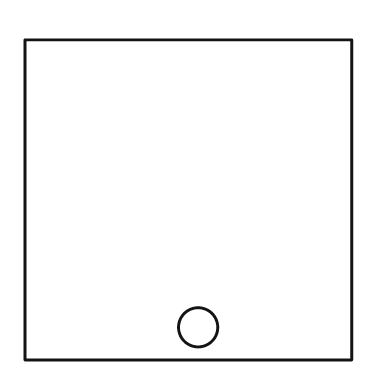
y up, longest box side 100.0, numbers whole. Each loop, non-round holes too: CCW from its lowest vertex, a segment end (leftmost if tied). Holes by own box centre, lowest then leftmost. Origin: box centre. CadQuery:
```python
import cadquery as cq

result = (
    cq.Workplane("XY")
    .moveTo(-50.0, -49.0)
    .lineTo(50.0, -49.0)
    .lineTo(50.0, 49.0)
    .lineTo(-50.0, 49.0)
    .close()
    .moveTo(3.0, -39.0)
    .circle(6.0)
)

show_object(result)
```